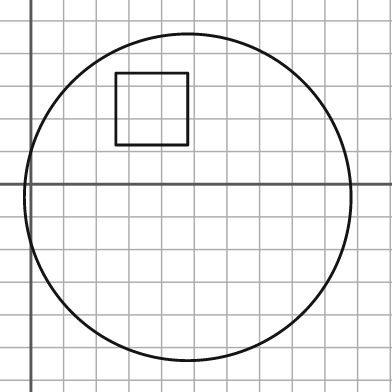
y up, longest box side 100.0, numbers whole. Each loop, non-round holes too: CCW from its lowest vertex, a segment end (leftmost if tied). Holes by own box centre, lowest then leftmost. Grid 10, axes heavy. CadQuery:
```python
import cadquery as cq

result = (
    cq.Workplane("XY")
    .moveTo(48.0, -4.0)
    .circle(50.0)
    .moveTo(26.0, 12.0)
    .lineTo(48.0, 12.0)
    .lineTo(48.0, 34.0)
    .lineTo(26.0, 34.0)
    .close()
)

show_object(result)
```